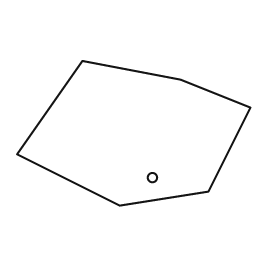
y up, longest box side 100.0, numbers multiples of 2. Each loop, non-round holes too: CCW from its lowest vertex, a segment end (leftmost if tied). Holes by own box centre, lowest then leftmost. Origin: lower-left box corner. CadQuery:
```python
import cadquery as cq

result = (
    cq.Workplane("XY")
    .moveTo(44.0, 0.0)
    .lineTo(82.0, 6.0)
    .lineTo(100.0, 42.0)
    .lineTo(70.0, 54.0)
    .lineTo(28.0, 62.0)
    .lineTo(0.0, 22.0)
    .close()
    .moveTo(58.0, 12.0)
    .circle(2.0)
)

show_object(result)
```